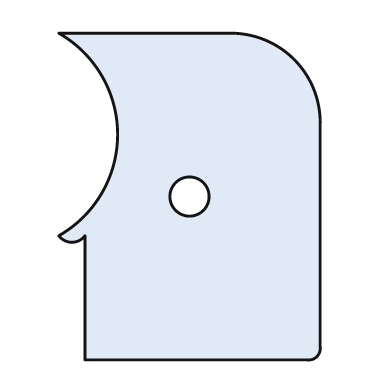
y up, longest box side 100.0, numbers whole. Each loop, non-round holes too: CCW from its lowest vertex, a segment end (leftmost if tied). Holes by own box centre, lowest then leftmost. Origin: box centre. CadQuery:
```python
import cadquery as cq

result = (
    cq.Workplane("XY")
    .moveTo(-32.0, -50.0)
    .lineTo(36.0, -50.0)
    .threePointArc((39.0, -49.0), (40.0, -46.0))
    .lineTo(40.0, 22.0)
    .threePointArc((32.0, 42.0), (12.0, 50.0))
    .lineTo(-40.0, 50.0)
    .threePointArc((-22.0, 19.0), (-40.0, -12.0))
    .threePointArc((-36.0, -14.0), (-32.0, -12.0))
    .close()
    .moveTo(0.0, 0.0)
    .circle(6.0)
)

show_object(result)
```